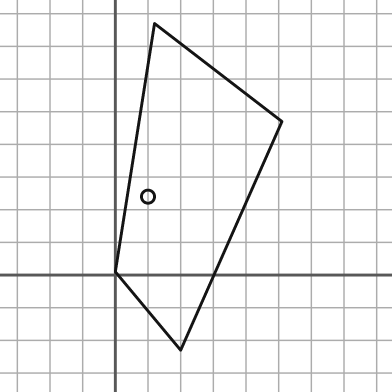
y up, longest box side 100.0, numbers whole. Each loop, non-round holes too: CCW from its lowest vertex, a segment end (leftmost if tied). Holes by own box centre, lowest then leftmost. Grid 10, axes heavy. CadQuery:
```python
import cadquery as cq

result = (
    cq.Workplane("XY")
    .moveTo(20.0, -23.0)
    .lineTo(51.0, 47.0)
    .lineTo(12.0, 77.0)
    .lineTo(0.0, 1.0)
    .close()
    .moveTo(10.0, 24.0)
    .circle(2.0)
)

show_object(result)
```